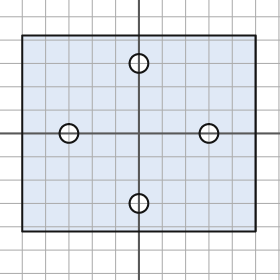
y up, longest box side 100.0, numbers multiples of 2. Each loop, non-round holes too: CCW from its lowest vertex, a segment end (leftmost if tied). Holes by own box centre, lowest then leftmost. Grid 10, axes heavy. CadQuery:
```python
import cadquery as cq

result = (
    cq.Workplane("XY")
    .moveTo(-50.0, -42.0)
    .lineTo(50.0, -42.0)
    .lineTo(50.0, 42.0)
    .lineTo(-50.0, 42.0)
    .close()
    .moveTo(0.0, -30.0)
    .circle(4.0)
    .moveTo(-30.0, 0.0)
    .circle(4.0)
    .moveTo(30.0, 0.0)
    .circle(4.0)
    .moveTo(0.0, 30.0)
    .circle(4.0)
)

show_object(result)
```